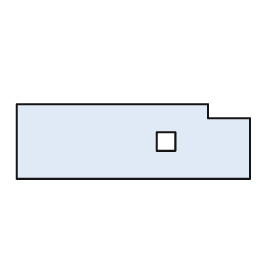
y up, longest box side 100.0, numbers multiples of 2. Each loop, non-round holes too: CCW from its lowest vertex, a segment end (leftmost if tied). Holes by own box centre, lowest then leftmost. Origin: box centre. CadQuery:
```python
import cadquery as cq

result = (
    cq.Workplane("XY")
    .moveTo(-50.0, -16.0)
    .lineTo(50.0, -16.0)
    .lineTo(50.0, 10.0)
    .lineTo(32.0, 10.0)
    .lineTo(32.0, 16.0)
    .lineTo(-50.0, 16.0)
    .close()
    .moveTo(10.0, -4.0)
    .lineTo(18.0, -4.0)
    .lineTo(18.0, 4.0)
    .lineTo(10.0, 4.0)
    .close()
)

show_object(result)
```